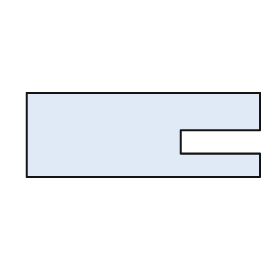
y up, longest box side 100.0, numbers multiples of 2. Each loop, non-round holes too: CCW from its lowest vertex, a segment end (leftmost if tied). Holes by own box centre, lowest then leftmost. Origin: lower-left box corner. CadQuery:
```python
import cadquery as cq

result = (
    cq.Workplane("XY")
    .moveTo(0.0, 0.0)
    .lineTo(100.0, 0.0)
    .lineTo(100.0, 10.0)
    .lineTo(66.0, 10.0)
    .lineTo(66.0, 20.0)
    .lineTo(100.0, 20.0)
    .lineTo(100.0, 36.0)
    .lineTo(0.0, 36.0)
    .close()
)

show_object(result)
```